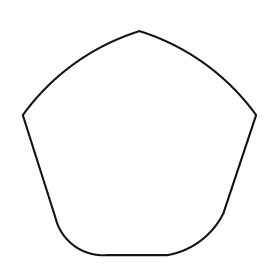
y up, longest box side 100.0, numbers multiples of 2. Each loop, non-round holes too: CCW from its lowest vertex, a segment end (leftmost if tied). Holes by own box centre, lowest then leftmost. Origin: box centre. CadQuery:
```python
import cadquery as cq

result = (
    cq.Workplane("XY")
    .moveTo(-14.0, -48.0)
    .lineTo(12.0, -48.0)
    .threePointArc((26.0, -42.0), (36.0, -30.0))
    .lineTo(50.0, 12.0)
    .threePointArc((28.0, 34.0), (0.0, 48.0))
    .threePointArc((-28.0, 34.0), (-50.0, 12.0))
    .lineTo(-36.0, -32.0)
    .threePointArc((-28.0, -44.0), (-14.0, -48.0))
    .close()
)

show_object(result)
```